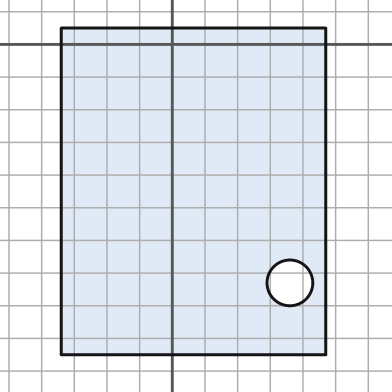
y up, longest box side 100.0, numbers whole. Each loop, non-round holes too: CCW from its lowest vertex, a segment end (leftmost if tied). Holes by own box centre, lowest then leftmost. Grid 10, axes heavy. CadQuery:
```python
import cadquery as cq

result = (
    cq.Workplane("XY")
    .moveTo(-34.0, -95.0)
    .lineTo(47.0, -95.0)
    .lineTo(47.0, 5.0)
    .lineTo(-34.0, 5.0)
    .close()
    .moveTo(36.0, -73.0)
    .circle(7.0)
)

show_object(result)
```